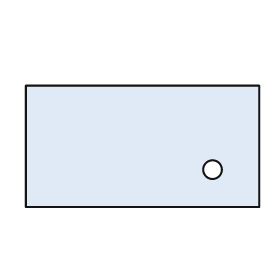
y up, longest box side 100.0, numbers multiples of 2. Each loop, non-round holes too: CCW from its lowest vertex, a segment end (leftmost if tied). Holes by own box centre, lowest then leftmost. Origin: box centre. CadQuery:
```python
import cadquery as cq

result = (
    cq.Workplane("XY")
    .moveTo(-50.0, -26.0)
    .lineTo(50.0, -26.0)
    .lineTo(50.0, 26.0)
    .lineTo(-50.0, 26.0)
    .close()
    .moveTo(30.0, -10.0)
    .circle(4.0)
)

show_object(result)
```